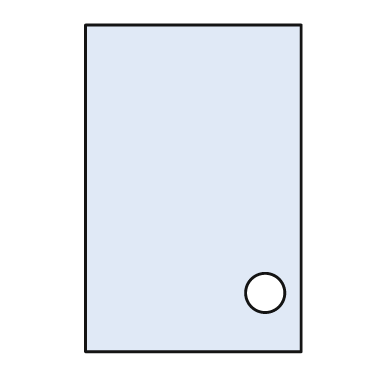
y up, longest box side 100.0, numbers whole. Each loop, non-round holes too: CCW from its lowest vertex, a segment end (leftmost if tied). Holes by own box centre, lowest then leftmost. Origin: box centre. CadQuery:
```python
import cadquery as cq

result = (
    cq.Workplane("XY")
    .moveTo(-33.0, -50.0)
    .lineTo(33.0, -50.0)
    .lineTo(33.0, 50.0)
    .lineTo(-33.0, 50.0)
    .close()
    .moveTo(22.0, -32.0)
    .circle(6.0)
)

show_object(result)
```